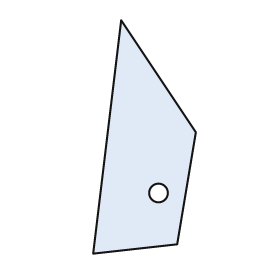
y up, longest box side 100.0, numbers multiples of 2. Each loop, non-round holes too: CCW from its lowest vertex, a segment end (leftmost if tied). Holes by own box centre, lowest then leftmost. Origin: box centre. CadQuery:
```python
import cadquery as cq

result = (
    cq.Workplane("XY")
    .moveTo(-22.0, -50.0)
    .lineTo(14.0, -46.0)
    .lineTo(22.0, 2.0)
    .lineTo(-10.0, 50.0)
    .close()
    .moveTo(6.0, -24.0)
    .circle(4.0)
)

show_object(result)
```